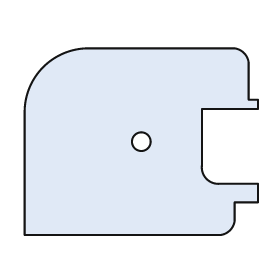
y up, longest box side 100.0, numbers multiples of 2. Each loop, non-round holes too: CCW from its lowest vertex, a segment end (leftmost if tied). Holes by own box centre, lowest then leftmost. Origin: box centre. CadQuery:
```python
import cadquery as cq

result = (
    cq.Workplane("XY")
    .moveTo(-50.0, -40.0)
    .lineTo(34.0, -40.0)
    .threePointArc((38.0, -38.0), (40.0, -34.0))
    .lineTo(40.0, -26.0)
    .lineTo(50.0, -26.0)
    .lineTo(50.0, -18.0)
    .lineTo(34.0, -18.0)
    .threePointArc((28.0, -16.0), (26.0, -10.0))
    .lineTo(26.0, 14.0)
    .lineTo(50.0, 14.0)
    .lineTo(50.0, 18.0)
    .lineTo(46.0, 18.0)
    .lineTo(46.0, 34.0)
    .threePointArc((44.0, 38.0), (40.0, 40.0))
    .lineTo(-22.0, 40.0)
    .threePointArc((-42.0, 32.0), (-50.0, 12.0))
    .close()
    .moveTo(0.0, 0.0)
    .circle(4.0)
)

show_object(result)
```